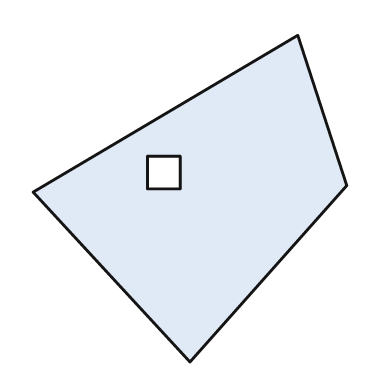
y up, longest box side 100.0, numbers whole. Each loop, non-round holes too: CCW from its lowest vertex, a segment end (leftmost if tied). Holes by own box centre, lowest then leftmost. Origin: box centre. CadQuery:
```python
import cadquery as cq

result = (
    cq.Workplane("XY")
    .moveTo(0.0, -50.0)
    .lineTo(48.0, 4.0)
    .lineTo(33.0, 50.0)
    .lineTo(-48.0, 2.0)
    .close()
    .moveTo(-13.0, 3.0)
    .lineTo(-3.0, 3.0)
    .lineTo(-3.0, 13.0)
    .lineTo(-13.0, 13.0)
    .close()
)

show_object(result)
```